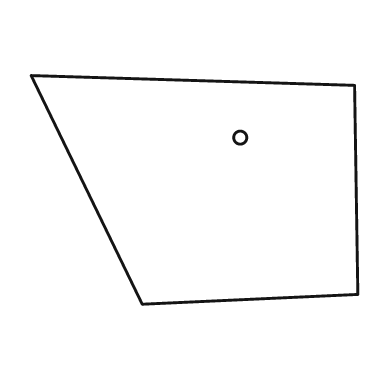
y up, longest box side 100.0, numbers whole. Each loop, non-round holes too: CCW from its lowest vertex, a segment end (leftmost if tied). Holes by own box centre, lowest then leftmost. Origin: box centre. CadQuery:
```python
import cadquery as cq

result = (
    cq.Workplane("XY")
    .moveTo(-16.0, -35.0)
    .lineTo(50.0, -32.0)
    .lineTo(49.0, 32.0)
    .lineTo(-50.0, 35.0)
    .close()
    .moveTo(14.0, 16.0)
    .circle(2.0)
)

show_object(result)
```